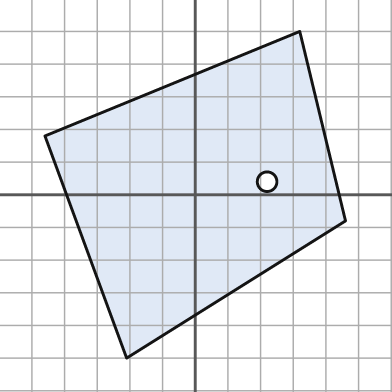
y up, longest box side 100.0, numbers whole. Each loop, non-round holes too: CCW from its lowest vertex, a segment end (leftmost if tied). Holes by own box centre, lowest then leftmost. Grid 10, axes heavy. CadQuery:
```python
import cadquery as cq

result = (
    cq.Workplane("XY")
    .moveTo(-21.0, -50.0)
    .lineTo(46.0, -8.0)
    .lineTo(32.0, 50.0)
    .lineTo(-46.0, 18.0)
    .close()
    .moveTo(22.0, 4.0)
    .circle(3.0)
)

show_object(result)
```